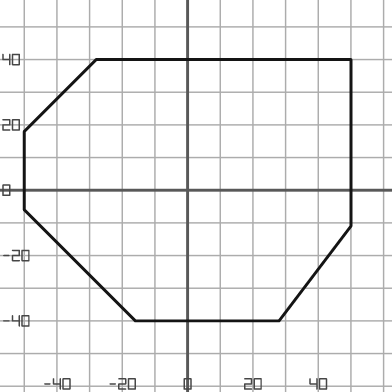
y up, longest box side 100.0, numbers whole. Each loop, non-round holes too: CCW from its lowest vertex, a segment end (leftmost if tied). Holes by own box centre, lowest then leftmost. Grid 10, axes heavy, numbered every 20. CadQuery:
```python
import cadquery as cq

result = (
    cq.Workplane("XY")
    .moveTo(-16.0, -40.0)
    .lineTo(28.0, -40.0)
    .lineTo(50.0, -11.0)
    .lineTo(50.0, 40.0)
    .lineTo(-28.0, 40.0)
    .lineTo(-50.0, 18.0)
    .lineTo(-50.0, -6.0)
    .close()
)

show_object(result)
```